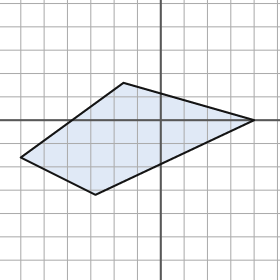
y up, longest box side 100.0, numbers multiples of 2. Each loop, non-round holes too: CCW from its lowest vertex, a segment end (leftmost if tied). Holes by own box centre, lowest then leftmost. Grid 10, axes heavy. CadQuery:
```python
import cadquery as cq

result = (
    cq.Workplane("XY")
    .moveTo(-28.0, -32.0)
    .lineTo(40.0, 0.0)
    .lineTo(-16.0, 16.0)
    .lineTo(-60.0, -16.0)
    .close()
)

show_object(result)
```